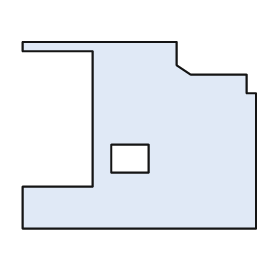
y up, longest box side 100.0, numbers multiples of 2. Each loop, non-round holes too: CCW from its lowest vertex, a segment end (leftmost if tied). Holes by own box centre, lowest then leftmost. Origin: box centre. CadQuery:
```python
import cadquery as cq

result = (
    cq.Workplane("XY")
    .moveTo(-50.0, -40.0)
    .lineTo(50.0, -40.0)
    .lineTo(50.0, 18.0)
    .lineTo(46.0, 18.0)
    .lineTo(46.0, 26.0)
    .lineTo(22.0, 26.0)
    .lineTo(16.0, 30.0)
    .lineTo(16.0, 40.0)
    .lineTo(-50.0, 40.0)
    .lineTo(-50.0, 36.0)
    .lineTo(-20.0, 36.0)
    .lineTo(-20.0, -22.0)
    .lineTo(-50.0, -22.0)
    .close()
    .moveTo(-12.0, -16.0)
    .lineTo(4.0, -16.0)
    .lineTo(4.0, -4.0)
    .lineTo(-12.0, -4.0)
    .close()
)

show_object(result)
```